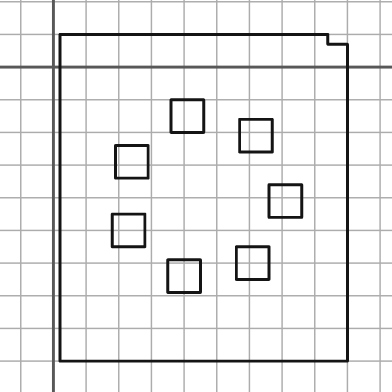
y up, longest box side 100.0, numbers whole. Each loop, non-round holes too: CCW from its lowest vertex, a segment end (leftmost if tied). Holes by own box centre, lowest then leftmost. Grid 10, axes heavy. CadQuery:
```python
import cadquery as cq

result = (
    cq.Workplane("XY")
    .moveTo(2.0, -90.0)
    .lineTo(90.0, -90.0)
    .lineTo(90.0, 7.0)
    .lineTo(84.0, 7.0)
    .lineTo(84.0, 10.0)
    .lineTo(2.0, 10.0)
    .close()
    .moveTo(35.0, -69.0)
    .lineTo(45.0, -69.0)
    .lineTo(45.0, -59.0)
    .lineTo(35.0, -59.0)
    .close()
    .moveTo(56.0, -65.0)
    .lineTo(66.0, -65.0)
    .lineTo(66.0, -55.0)
    .lineTo(56.0, -55.0)
    .close()
    .moveTo(18.0, -55.0)
    .lineTo(28.0, -55.0)
    .lineTo(28.0, -45.0)
    .lineTo(18.0, -45.0)
    .close()
    .moveTo(66.0, -46.0)
    .lineTo(76.0, -46.0)
    .lineTo(76.0, -36.0)
    .lineTo(66.0, -36.0)
    .close()
    .moveTo(19.0, -34.0)
    .lineTo(29.0, -34.0)
    .lineTo(29.0, -24.0)
    .lineTo(19.0, -24.0)
    .close()
    .moveTo(57.0, -26.0)
    .lineTo(67.0, -26.0)
    .lineTo(67.0, -16.0)
    .lineTo(57.0, -16.0)
    .close()
    .moveTo(36.0, -20.0)
    .lineTo(46.0, -20.0)
    .lineTo(46.0, -10.0)
    .lineTo(36.0, -10.0)
    .close()
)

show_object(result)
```